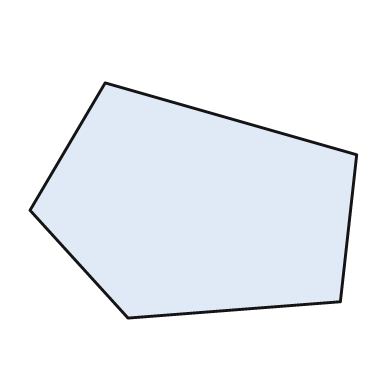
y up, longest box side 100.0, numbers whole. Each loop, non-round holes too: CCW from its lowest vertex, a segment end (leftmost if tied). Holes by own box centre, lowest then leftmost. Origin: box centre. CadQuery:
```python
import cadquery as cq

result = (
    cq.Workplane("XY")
    .moveTo(-20.0, -36.0)
    .lineTo(45.0, -31.0)
    .lineTo(50.0, 14.0)
    .lineTo(-27.0, 36.0)
    .lineTo(-50.0, -3.0)
    .close()
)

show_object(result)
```